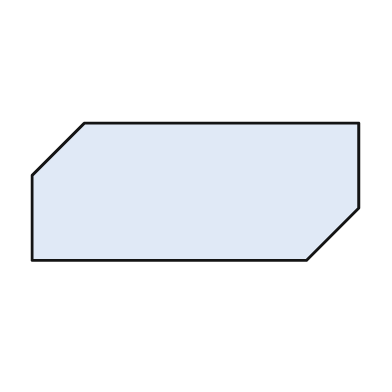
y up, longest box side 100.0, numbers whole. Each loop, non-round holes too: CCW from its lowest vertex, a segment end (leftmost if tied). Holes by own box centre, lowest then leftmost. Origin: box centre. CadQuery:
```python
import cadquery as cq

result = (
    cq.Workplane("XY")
    .moveTo(-50.0, -21.0)
    .lineTo(34.0, -21.0)
    .lineTo(50.0, -5.0)
    .lineTo(50.0, 21.0)
    .lineTo(-34.0, 21.0)
    .lineTo(-50.0, 5.0)
    .close()
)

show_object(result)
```